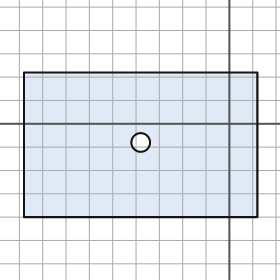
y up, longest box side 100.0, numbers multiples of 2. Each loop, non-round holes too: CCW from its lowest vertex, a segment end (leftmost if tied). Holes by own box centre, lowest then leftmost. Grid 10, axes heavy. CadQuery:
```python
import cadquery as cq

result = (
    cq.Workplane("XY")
    .moveTo(-88.0, -40.0)
    .lineTo(12.0, -40.0)
    .lineTo(12.0, 22.0)
    .lineTo(-88.0, 22.0)
    .close()
    .moveTo(-38.0, -8.0)
    .circle(4.0)
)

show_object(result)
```